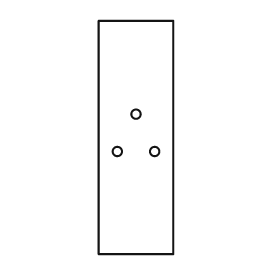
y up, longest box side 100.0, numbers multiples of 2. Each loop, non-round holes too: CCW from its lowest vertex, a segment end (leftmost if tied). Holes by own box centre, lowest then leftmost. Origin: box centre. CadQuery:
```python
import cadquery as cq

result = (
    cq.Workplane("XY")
    .moveTo(-16.0, -50.0)
    .lineTo(16.0, -50.0)
    .lineTo(16.0, 50.0)
    .lineTo(-16.0, 50.0)
    .close()
    .moveTo(-8.0, -6.0)
    .circle(2.0)
    .moveTo(8.0, -6.0)
    .circle(2.0)
    .moveTo(0.0, 10.0)
    .circle(2.0)
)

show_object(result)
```